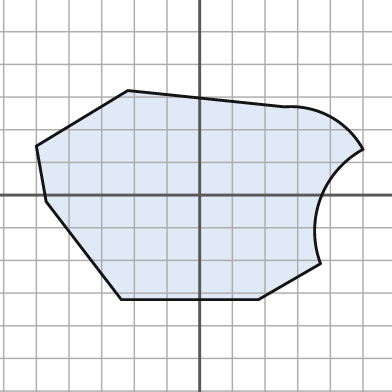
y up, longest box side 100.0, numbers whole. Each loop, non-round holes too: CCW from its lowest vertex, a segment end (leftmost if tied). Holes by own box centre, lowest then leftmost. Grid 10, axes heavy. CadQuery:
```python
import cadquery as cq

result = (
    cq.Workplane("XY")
    .moveTo(-24.0, -32.0)
    .lineTo(18.0, -32.0)
    .lineTo(37.0, -21.0)
    .threePointArc((37.0, -1.0), (50.0, 14.0))
    .threePointArc((40.0, 24.0), (26.0, 27.0))
    .lineTo(-22.0, 32.0)
    .lineTo(-50.0, 15.0)
    .lineTo(-47.0, -2.0)
    .close()
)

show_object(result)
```